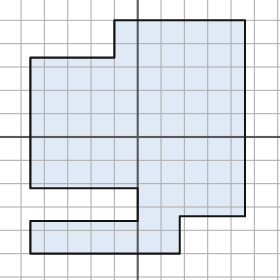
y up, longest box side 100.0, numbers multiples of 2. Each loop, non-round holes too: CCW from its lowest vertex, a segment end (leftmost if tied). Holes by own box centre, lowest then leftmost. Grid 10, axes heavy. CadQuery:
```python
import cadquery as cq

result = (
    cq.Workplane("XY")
    .moveTo(-46.0, -50.0)
    .lineTo(18.0, -50.0)
    .lineTo(18.0, -34.0)
    .lineTo(46.0, -34.0)
    .lineTo(46.0, 50.0)
    .lineTo(-10.0, 50.0)
    .lineTo(-10.0, 34.0)
    .lineTo(-46.0, 34.0)
    .lineTo(-46.0, -22.0)
    .lineTo(0.0, -22.0)
    .lineTo(0.0, -36.0)
    .lineTo(-46.0, -36.0)
    .close()
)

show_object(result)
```